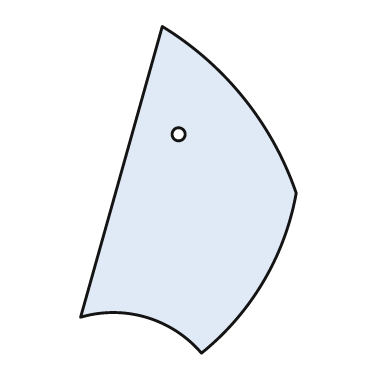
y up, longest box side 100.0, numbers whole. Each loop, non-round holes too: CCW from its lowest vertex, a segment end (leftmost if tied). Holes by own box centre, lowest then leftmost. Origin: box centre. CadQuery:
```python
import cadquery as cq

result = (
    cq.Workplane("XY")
    .moveTo(4.0, -50.0)
    .threePointArc((23.0, -28.0), (33.0, -1.0))
    .threePointArc((17.0, 28.0), (-8.0, 50.0))
    .lineTo(-33.0, -39.0)
    .threePointArc((-13.0, -39.0), (4.0, -50.0))
    .close()
    .moveTo(-3.0, 17.0)
    .circle(2.0)
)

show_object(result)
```